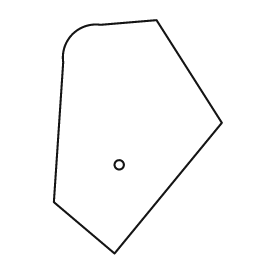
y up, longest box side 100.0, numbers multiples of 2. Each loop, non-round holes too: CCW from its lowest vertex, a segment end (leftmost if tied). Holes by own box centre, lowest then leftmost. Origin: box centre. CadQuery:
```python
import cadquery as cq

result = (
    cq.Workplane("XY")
    .moveTo(-10.0, -50.0)
    .lineTo(36.0, 6.0)
    .lineTo(8.0, 50.0)
    .lineTo(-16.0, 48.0)
    .threePointArc((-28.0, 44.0), (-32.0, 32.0))
    .lineTo(-36.0, -28.0)
    .close()
    .moveTo(-8.0, -12.0)
    .circle(2.0)
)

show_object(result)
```